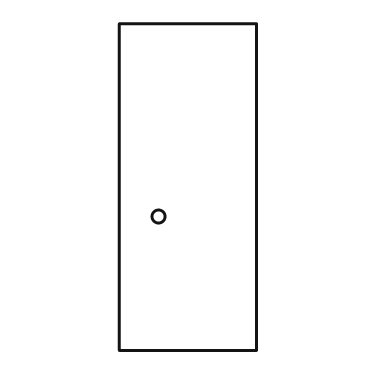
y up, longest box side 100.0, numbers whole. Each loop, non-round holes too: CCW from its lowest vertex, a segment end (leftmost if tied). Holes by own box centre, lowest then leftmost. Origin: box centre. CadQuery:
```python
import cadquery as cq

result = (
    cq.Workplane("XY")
    .moveTo(-21.0, -50.0)
    .lineTo(21.0, -50.0)
    .lineTo(21.0, 50.0)
    .lineTo(-21.0, 50.0)
    .close()
    .moveTo(-9.0, -9.0)
    .circle(2.0)
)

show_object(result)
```